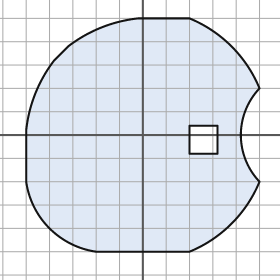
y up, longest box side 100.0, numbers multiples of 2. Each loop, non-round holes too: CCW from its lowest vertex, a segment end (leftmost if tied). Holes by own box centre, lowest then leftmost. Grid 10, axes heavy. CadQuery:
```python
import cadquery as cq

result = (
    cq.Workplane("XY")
    .moveTo(-20.0, -50.0)
    .lineTo(20.0, -50.0)
    .threePointArc((38.0, -38.0), (50.0, -20.0))
    .threePointArc((42.0, 0.0), (50.0, 20.0))
    .threePointArc((38.0, 38.0), (20.0, 50.0))
    .lineTo(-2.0, 50.0)
    .threePointArc((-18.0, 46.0), (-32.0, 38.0))
    .lineTo(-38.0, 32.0)
    .threePointArc((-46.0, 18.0), (-50.0, 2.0))
    .lineTo(-50.0, -20.0)
    .threePointArc((-40.0, -40.0), (-20.0, -50.0))
    .close()
    .moveTo(20.0, -8.0)
    .lineTo(32.0, -8.0)
    .lineTo(32.0, 4.0)
    .lineTo(20.0, 4.0)
    .close()
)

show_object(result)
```